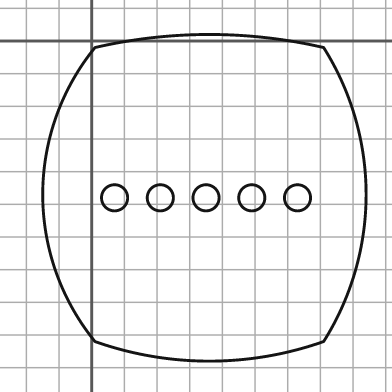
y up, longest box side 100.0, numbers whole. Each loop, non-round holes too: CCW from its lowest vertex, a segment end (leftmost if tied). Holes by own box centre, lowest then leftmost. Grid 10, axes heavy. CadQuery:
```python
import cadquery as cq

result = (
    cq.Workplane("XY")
    .moveTo(1.0, -92.0)
    .threePointArc((36.0, -98.0), (71.0, -92.0))
    .threePointArc((84.0, -47.0), (71.0, -2.0))
    .threePointArc((36.0, 2.0), (1.0, -2.0))
    .threePointArc((-15.0, -47.0), (1.0, -92.0))
    .close()
    .moveTo(7.0, -48.0)
    .circle(4.0)
    .moveTo(21.0, -48.0)
    .circle(4.0)
    .moveTo(35.0, -48.0)
    .circle(4.0)
    .moveTo(49.0, -48.0)
    .circle(4.0)
    .moveTo(63.0, -48.0)
    .circle(4.0)
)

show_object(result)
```